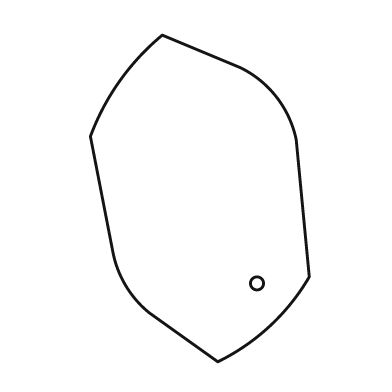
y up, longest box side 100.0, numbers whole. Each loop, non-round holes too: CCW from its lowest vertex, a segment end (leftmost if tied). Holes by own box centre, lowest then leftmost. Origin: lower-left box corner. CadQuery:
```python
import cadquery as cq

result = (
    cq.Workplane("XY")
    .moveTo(39.0, 0.0)
    .threePointArc((55.0, 11.0), (67.0, 26.0))
    .lineTo(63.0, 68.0)
    .threePointArc((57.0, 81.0), (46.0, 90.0))
    .lineTo(22.0, 100.0)
    .threePointArc((9.0, 86.0), (0.0, 69.0))
    .lineTo(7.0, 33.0)
    .threePointArc((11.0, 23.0), (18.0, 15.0))
    .close()
    .moveTo(51.0, 24.0)
    .circle(2.0)
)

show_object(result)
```